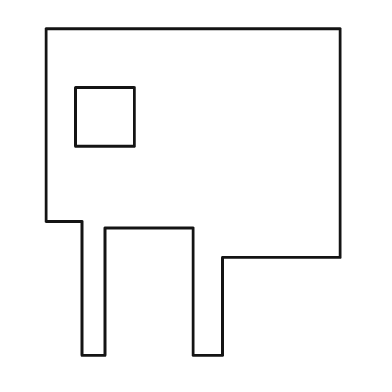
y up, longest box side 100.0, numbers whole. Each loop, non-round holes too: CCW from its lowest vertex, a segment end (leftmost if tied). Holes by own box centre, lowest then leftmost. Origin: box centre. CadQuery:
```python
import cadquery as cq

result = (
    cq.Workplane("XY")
    .moveTo(-34.0, -50.0)
    .lineTo(-27.0, -50.0)
    .lineTo(-27.0, -11.0)
    .lineTo(0.0, -11.0)
    .lineTo(0.0, -50.0)
    .lineTo(9.0, -50.0)
    .lineTo(9.0, -20.0)
    .lineTo(45.0, -20.0)
    .lineTo(45.0, 50.0)
    .lineTo(-45.0, 50.0)
    .lineTo(-45.0, -9.0)
    .lineTo(-34.0, -9.0)
    .close()
    .moveTo(-36.0, 14.0)
    .lineTo(-18.0, 14.0)
    .lineTo(-18.0, 32.0)
    .lineTo(-36.0, 32.0)
    .close()
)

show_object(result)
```